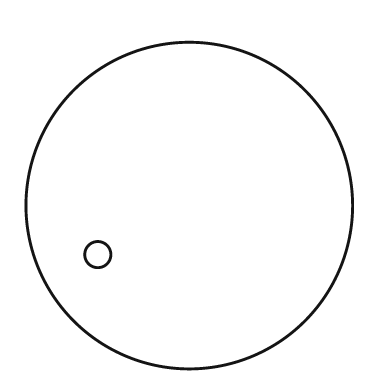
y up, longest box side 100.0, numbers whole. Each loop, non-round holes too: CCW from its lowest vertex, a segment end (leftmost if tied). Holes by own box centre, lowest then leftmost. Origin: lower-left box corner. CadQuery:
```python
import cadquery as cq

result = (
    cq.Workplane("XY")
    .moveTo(50.0, 50.0)
    .circle(50.0)
    .moveTo(22.0, 35.0)
    .circle(4.0)
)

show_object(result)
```